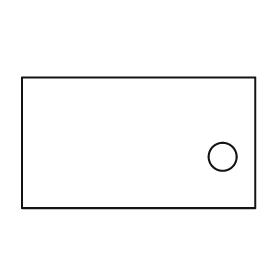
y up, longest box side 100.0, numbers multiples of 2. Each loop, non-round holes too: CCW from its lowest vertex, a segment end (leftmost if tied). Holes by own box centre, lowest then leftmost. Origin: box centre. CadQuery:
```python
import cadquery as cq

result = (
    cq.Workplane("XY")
    .moveTo(-50.0, -28.0)
    .lineTo(50.0, -28.0)
    .lineTo(50.0, 28.0)
    .lineTo(-50.0, 28.0)
    .close()
    .moveTo(36.0, -6.0)
    .circle(6.0)
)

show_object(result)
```